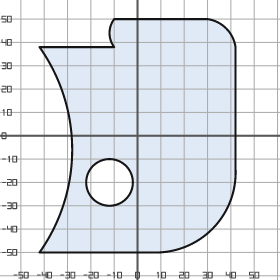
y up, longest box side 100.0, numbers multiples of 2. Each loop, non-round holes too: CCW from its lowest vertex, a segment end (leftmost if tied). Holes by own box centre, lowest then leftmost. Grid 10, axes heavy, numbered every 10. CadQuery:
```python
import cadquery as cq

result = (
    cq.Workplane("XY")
    .moveTo(-42.0, -50.0)
    .lineTo(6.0, -50.0)
    .threePointArc((32.0, -40.0), (42.0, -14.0))
    .lineTo(42.0, 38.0)
    .threePointArc((38.0, 46.0), (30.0, 50.0))
    .lineTo(-10.0, 50.0)
    .threePointArc((-12.0, 44.0), (-10.0, 38.0))
    .lineTo(-42.0, 38.0)
    .threePointArc((-28.0, -6.0), (-42.0, -50.0))
    .close()
    .moveTo(-12.0, -20.0)
    .circle(10.0)
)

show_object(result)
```